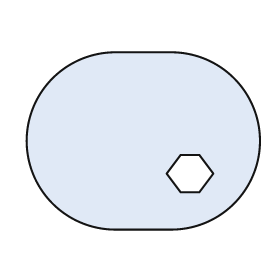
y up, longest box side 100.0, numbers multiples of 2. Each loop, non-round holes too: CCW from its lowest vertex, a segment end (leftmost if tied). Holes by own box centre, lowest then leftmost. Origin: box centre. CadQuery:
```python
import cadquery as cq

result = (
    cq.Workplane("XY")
    .moveTo(-12.0, -38.0)
    .lineTo(12.0, -38.0)
    .threePointArc((50.0, 0.0), (12.0, 38.0))
    .lineTo(-12.0, 38.0)
    .threePointArc((-50.0, 0.0), (-12.0, -38.0))
    .close()
    .moveTo(16.0, -22.0)
    .lineTo(24.0, -22.0)
    .lineTo(30.0, -14.0)
    .lineTo(24.0, -6.0)
    .lineTo(16.0, -6.0)
    .lineTo(10.0, -14.0)
    .close()
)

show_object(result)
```